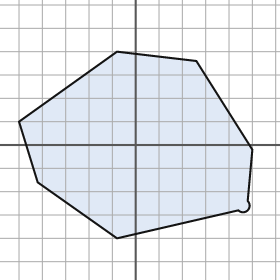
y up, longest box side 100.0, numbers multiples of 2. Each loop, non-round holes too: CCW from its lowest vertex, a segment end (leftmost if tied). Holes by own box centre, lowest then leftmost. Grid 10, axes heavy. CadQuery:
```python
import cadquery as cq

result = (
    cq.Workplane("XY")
    .moveTo(-8.0, -40.0)
    .lineTo(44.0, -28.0)
    .threePointArc((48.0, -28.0), (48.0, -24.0))
    .lineTo(50.0, -2.0)
    .lineTo(26.0, 36.0)
    .lineTo(-8.0, 40.0)
    .lineTo(-50.0, 10.0)
    .lineTo(-42.0, -16.0)
    .close()
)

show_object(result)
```